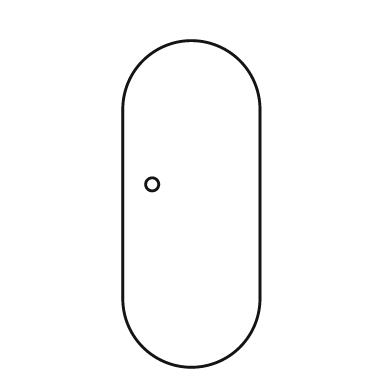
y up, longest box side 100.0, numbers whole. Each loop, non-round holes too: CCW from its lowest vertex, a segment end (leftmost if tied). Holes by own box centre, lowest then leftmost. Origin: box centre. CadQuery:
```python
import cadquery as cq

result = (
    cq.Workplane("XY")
    .moveTo(-21.0, -29.0)
    .threePointArc((0.0, -50.0), (21.0, -29.0))
    .lineTo(21.0, 29.0)
    .threePointArc((0.0, 50.0), (-21.0, 29.0))
    .close()
    .moveTo(-12.0, 6.0)
    .circle(2.0)
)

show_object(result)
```